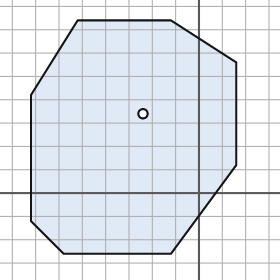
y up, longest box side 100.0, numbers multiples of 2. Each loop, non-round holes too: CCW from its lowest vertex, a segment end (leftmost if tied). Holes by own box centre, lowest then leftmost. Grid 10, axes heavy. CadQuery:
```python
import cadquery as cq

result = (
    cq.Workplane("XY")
    .moveTo(-58.0, -26.0)
    .lineTo(-12.0, -26.0)
    .lineTo(16.0, 12.0)
    .lineTo(16.0, 56.0)
    .lineTo(-12.0, 74.0)
    .lineTo(-52.0, 74.0)
    .lineTo(-72.0, 42.0)
    .lineTo(-72.0, -12.0)
    .close()
    .moveTo(-24.0, 34.0)
    .circle(2.0)
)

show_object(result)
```